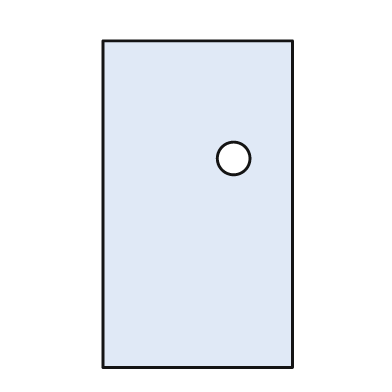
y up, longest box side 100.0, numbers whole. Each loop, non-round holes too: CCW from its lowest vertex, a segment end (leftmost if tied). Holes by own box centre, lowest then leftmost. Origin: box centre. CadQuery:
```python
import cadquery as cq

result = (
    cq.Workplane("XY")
    .moveTo(-29.0, -50.0)
    .lineTo(29.0, -50.0)
    .lineTo(29.0, 50.0)
    .lineTo(-29.0, 50.0)
    .close()
    .moveTo(11.0, 14.0)
    .circle(5.0)
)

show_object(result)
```